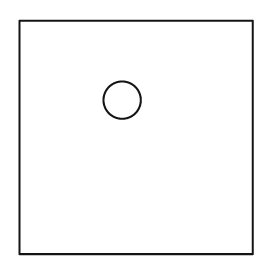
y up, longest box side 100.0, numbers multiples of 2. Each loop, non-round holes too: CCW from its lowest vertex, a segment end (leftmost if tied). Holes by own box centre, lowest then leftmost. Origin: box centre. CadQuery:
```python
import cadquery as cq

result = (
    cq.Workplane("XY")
    .moveTo(-50.0, -50.0)
    .lineTo(50.0, -50.0)
    .lineTo(50.0, 50.0)
    .lineTo(-50.0, 50.0)
    .close()
    .moveTo(-6.0, 16.0)
    .circle(8.0)
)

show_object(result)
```